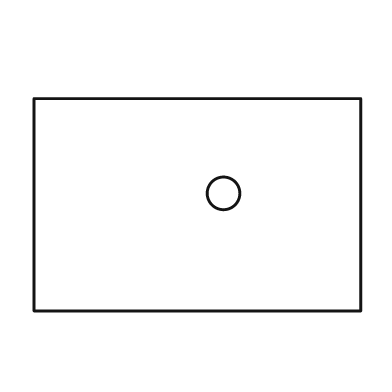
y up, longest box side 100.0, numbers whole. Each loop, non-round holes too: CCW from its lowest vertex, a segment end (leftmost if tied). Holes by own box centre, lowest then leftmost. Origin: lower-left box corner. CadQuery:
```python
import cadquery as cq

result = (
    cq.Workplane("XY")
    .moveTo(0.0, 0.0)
    .lineTo(100.0, 0.0)
    .lineTo(100.0, 65.0)
    .lineTo(0.0, 65.0)
    .close()
    .moveTo(58.0, 36.0)
    .circle(5.0)
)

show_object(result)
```